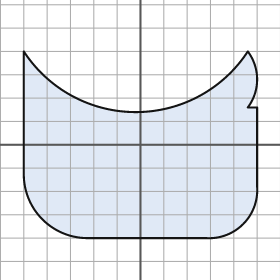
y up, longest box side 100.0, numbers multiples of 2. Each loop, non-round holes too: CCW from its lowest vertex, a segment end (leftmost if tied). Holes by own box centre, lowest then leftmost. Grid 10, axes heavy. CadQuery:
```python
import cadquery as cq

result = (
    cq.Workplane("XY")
    .moveTo(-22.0, -40.0)
    .lineTo(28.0, -40.0)
    .threePointArc((44.0, -34.0), (50.0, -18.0))
    .lineTo(50.0, 16.0)
    .lineTo(46.0, 16.0)
    .threePointArc((50.0, 28.0), (46.0, 40.0))
    .threePointArc((-2.0, 14.0), (-50.0, 40.0))
    .lineTo(-50.0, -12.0)
    .threePointArc((-42.0, -32.0), (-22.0, -40.0))
    .close()
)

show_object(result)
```